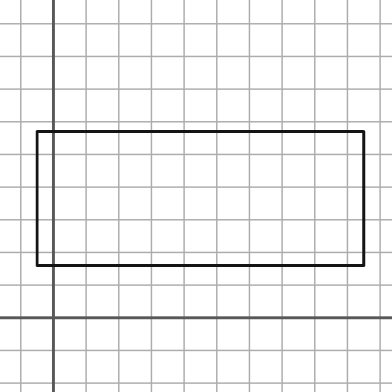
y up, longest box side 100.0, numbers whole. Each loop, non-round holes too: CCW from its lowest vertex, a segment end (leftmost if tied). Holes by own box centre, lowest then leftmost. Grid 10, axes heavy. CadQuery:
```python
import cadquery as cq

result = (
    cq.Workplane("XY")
    .moveTo(-5.0, 16.0)
    .lineTo(95.0, 16.0)
    .lineTo(95.0, 57.0)
    .lineTo(-5.0, 57.0)
    .close()
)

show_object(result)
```